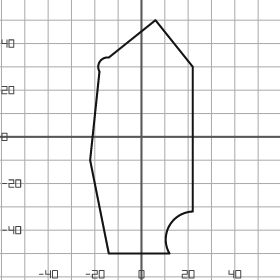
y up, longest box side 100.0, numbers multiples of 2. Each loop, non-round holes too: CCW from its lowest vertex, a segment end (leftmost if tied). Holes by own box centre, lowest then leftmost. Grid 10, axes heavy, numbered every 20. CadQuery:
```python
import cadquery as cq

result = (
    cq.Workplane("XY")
    .moveTo(-14.0, -50.0)
    .lineTo(12.0, -50.0)
    .threePointArc((12.0, -38.0), (22.0, -32.0))
    .lineTo(22.0, 30.0)
    .lineTo(6.0, 50.0)
    .lineTo(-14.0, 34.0)
    .threePointArc((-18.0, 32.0), (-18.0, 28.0))
    .lineTo(-22.0, -10.0)
    .close()
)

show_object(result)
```